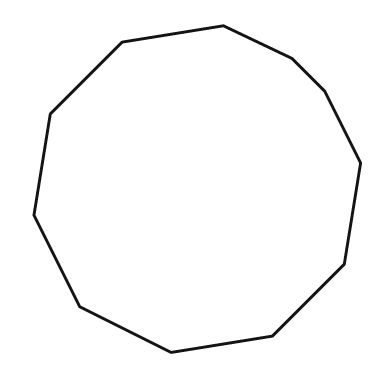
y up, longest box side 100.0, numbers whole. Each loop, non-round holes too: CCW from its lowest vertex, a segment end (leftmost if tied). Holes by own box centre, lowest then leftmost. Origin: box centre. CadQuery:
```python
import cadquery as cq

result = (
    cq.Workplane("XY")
    .moveTo(-8.0, -50.0)
    .lineTo(23.0, -45.0)
    .lineTo(45.0, -23.0)
    .lineTo(50.0, 8.0)
    .lineTo(39.0, 30.0)
    .lineTo(29.0, 40.0)
    .lineTo(8.0, 50.0)
    .lineTo(-23.0, 45.0)
    .lineTo(-45.0, 23.0)
    .lineTo(-50.0, -8.0)
    .lineTo(-36.0, -36.0)
    .close()
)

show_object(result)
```